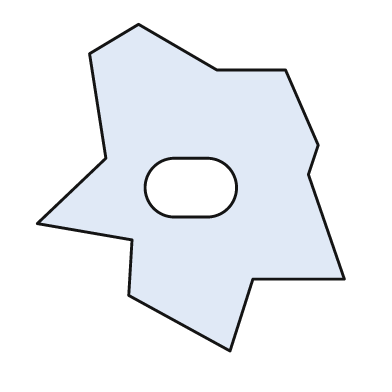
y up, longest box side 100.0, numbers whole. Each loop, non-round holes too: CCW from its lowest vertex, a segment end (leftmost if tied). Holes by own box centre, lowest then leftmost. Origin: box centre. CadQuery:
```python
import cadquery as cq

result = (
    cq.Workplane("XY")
    .moveTo(12.0, -50.0)
    .lineTo(19.0, -28.0)
    .lineTo(47.0, -28.0)
    .lineTo(36.0, 4.0)
    .lineTo(39.0, 13.0)
    .lineTo(29.0, 36.0)
    .lineTo(8.0, 36.0)
    .lineTo(-16.0, 50.0)
    .lineTo(-31.0, 41.0)
    .lineTo(-26.0, 9.0)
    .lineTo(-47.0, -11.0)
    .lineTo(-18.0, -16.0)
    .lineTo(-19.0, -33.0)
    .close()
    .moveTo(-5.0, -9.0)
    .lineTo(5.0, -9.0)
    .threePointArc((14.0, 0.0), (5.0, 9.0))
    .lineTo(-5.0, 9.0)
    .threePointArc((-14.0, 0.0), (-5.0, -9.0))
    .close()
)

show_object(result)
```